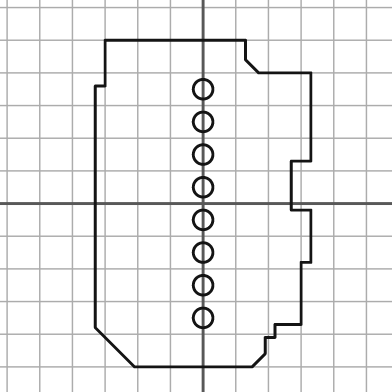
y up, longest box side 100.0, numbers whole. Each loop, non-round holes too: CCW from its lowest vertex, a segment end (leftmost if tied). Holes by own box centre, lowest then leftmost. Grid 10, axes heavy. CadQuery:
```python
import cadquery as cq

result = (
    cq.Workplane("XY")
    .moveTo(-21.0, -50.0)
    .lineTo(15.0, -50.0)
    .lineTo(19.0, -46.0)
    .lineTo(19.0, -41.0)
    .lineTo(22.0, -41.0)
    .lineTo(22.0, -37.0)
    .lineTo(30.0, -37.0)
    .lineTo(30.0, -18.0)
    .lineTo(33.0, -18.0)
    .lineTo(33.0, -2.0)
    .lineTo(27.0, -2.0)
    .lineTo(27.0, 13.0)
    .lineTo(33.0, 13.0)
    .lineTo(33.0, 40.0)
    .lineTo(17.0, 40.0)
    .lineTo(13.0, 44.0)
    .lineTo(13.0, 50.0)
    .lineTo(-30.0, 50.0)
    .lineTo(-30.0, 36.0)
    .lineTo(-33.0, 36.0)
    .lineTo(-33.0, -38.0)
    .close()
    .moveTo(0.0, -35.0)
    .circle(3.0)
    .moveTo(0.0, -25.0)
    .circle(3.0)
    .moveTo(0.0, -15.0)
    .circle(3.0)
    .moveTo(0.0, -5.0)
    .circle(3.0)
    .moveTo(0.0, 5.0)
    .circle(3.0)
    .moveTo(0.0, 15.0)
    .circle(3.0)
    .moveTo(0.0, 25.0)
    .circle(3.0)
    .moveTo(0.0, 35.0)
    .circle(3.0)
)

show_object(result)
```